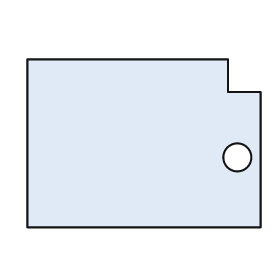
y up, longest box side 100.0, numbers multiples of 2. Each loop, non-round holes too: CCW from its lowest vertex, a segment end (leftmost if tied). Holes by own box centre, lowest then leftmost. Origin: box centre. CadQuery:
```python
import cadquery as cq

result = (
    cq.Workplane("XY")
    .moveTo(-50.0, -36.0)
    .lineTo(50.0, -36.0)
    .lineTo(50.0, 22.0)
    .lineTo(36.0, 22.0)
    .lineTo(36.0, 36.0)
    .lineTo(-50.0, 36.0)
    .close()
    .moveTo(40.0, -6.0)
    .circle(6.0)
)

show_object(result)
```